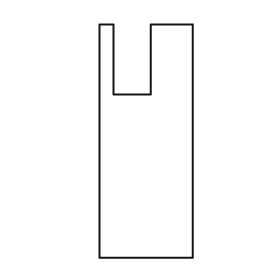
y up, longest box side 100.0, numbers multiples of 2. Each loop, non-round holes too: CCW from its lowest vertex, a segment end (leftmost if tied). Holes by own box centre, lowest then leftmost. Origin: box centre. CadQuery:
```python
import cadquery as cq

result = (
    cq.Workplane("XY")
    .moveTo(-20.0, -50.0)
    .lineTo(20.0, -50.0)
    .lineTo(20.0, 50.0)
    .lineTo(2.0, 50.0)
    .lineTo(2.0, 20.0)
    .lineTo(-14.0, 20.0)
    .lineTo(-14.0, 50.0)
    .lineTo(-20.0, 50.0)
    .close()
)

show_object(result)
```